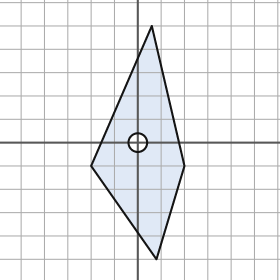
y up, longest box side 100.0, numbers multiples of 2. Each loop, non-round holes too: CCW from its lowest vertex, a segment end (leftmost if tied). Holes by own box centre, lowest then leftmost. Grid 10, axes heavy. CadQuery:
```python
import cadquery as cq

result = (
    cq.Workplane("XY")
    .moveTo(8.0, -50.0)
    .lineTo(20.0, -10.0)
    .lineTo(6.0, 50.0)
    .lineTo(-20.0, -10.0)
    .close()
    .moveTo(0.0, 0.0)
    .circle(4.0)
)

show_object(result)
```